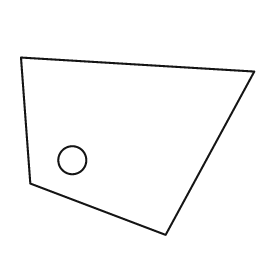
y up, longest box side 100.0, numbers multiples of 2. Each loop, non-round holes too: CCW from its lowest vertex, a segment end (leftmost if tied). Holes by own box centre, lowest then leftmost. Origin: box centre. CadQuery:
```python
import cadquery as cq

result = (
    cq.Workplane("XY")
    .moveTo(12.0, -38.0)
    .lineTo(50.0, 32.0)
    .lineTo(-50.0, 38.0)
    .lineTo(-46.0, -16.0)
    .close()
    .moveTo(-28.0, -6.0)
    .circle(6.0)
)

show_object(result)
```